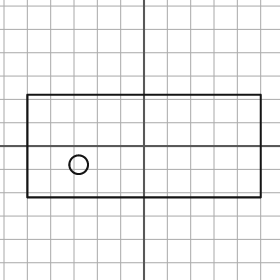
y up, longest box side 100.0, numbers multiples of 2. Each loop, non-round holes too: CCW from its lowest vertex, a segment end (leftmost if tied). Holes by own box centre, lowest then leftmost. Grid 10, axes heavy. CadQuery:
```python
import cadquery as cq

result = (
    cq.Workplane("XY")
    .moveTo(-50.0, -22.0)
    .lineTo(50.0, -22.0)
    .lineTo(50.0, 22.0)
    .lineTo(-50.0, 22.0)
    .close()
    .moveTo(-28.0, -8.0)
    .circle(4.0)
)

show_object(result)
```